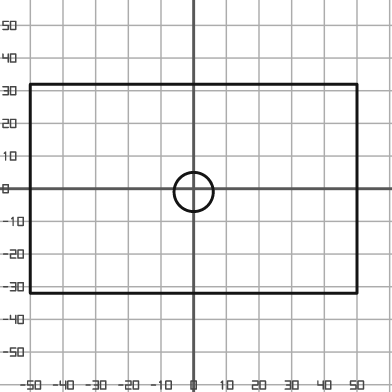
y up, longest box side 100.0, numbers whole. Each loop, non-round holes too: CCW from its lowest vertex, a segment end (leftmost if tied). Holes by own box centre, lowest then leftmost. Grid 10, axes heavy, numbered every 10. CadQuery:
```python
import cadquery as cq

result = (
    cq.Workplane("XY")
    .moveTo(-50.0, -32.0)
    .lineTo(50.0, -32.0)
    .lineTo(50.0, 32.0)
    .lineTo(-50.0, 32.0)
    .close()
    .moveTo(0.0, -1.0)
    .circle(6.0)
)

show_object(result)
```